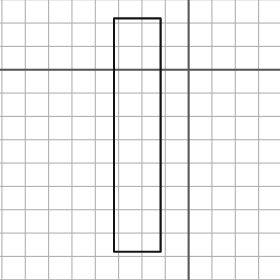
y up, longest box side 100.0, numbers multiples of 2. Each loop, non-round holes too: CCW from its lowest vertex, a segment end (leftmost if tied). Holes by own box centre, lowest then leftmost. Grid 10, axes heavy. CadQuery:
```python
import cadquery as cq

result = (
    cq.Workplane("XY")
    .moveTo(-32.0, -78.0)
    .lineTo(-12.0, -78.0)
    .lineTo(-12.0, 22.0)
    .lineTo(-32.0, 22.0)
    .close()
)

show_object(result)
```